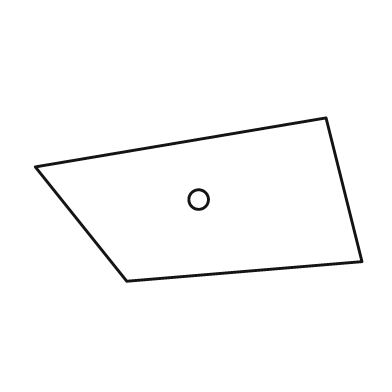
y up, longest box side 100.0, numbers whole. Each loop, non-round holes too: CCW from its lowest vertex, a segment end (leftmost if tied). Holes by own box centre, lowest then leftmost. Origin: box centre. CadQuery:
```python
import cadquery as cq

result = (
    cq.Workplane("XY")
    .moveTo(-22.0, -25.0)
    .lineTo(50.0, -19.0)
    .lineTo(39.0, 25.0)
    .lineTo(-50.0, 10.0)
    .close()
    .moveTo(0.0, 0.0)
    .circle(3.0)
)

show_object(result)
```